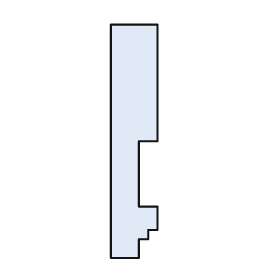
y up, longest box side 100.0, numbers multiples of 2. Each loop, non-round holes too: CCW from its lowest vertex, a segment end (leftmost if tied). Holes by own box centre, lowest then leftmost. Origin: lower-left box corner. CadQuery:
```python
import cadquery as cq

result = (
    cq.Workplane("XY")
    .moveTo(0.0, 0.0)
    .lineTo(12.0, 0.0)
    .lineTo(12.0, 8.0)
    .lineTo(16.0, 8.0)
    .lineTo(16.0, 12.0)
    .lineTo(20.0, 12.0)
    .lineTo(20.0, 22.0)
    .lineTo(12.0, 22.0)
    .lineTo(12.0, 50.0)
    .lineTo(20.0, 50.0)
    .lineTo(20.0, 100.0)
    .lineTo(0.0, 100.0)
    .close()
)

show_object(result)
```